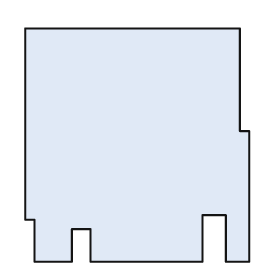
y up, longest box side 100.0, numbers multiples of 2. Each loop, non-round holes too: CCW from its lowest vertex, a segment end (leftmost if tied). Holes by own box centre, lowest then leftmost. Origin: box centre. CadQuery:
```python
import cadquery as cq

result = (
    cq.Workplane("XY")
    .moveTo(-44.0, -50.0)
    .lineTo(-28.0, -50.0)
    .lineTo(-28.0, -36.0)
    .lineTo(-20.0, -36.0)
    .lineTo(-20.0, -50.0)
    .lineTo(28.0, -50.0)
    .lineTo(28.0, -30.0)
    .lineTo(38.0, -30.0)
    .lineTo(38.0, -50.0)
    .lineTo(48.0, -50.0)
    .lineTo(48.0, 6.0)
    .lineTo(44.0, 6.0)
    .lineTo(44.0, 50.0)
    .lineTo(-48.0, 50.0)
    .lineTo(-48.0, -32.0)
    .lineTo(-44.0, -32.0)
    .close()
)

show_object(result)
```